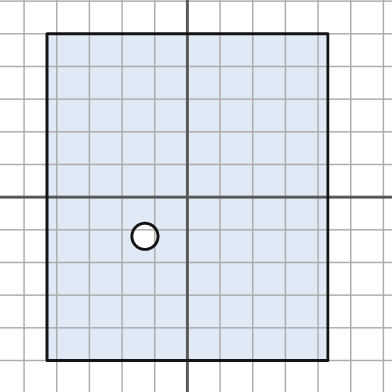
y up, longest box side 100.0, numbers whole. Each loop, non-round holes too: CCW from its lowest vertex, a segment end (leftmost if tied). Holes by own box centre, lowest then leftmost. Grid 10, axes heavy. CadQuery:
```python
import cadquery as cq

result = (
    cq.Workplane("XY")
    .moveTo(-43.0, -50.0)
    .lineTo(43.0, -50.0)
    .lineTo(43.0, 50.0)
    .lineTo(-43.0, 50.0)
    .close()
    .moveTo(-13.0, -12.0)
    .circle(4.0)
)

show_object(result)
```